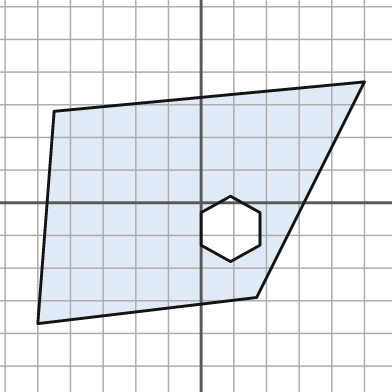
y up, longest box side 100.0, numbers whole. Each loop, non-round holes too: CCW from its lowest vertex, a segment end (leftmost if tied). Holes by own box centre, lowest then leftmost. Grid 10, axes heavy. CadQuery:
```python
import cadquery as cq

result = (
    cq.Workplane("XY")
    .moveTo(-50.0, -37.0)
    .lineTo(17.0, -29.0)
    .lineTo(50.0, 37.0)
    .lineTo(-45.0, 28.0)
    .close()
    .moveTo(9.0, -18.0)
    .lineTo(18.0, -13.0)
    .lineTo(18.0, -3.0)
    .lineTo(9.0, 2.0)
    .lineTo(0.0, -3.0)
    .lineTo(0.0, -13.0)
    .close()
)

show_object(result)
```